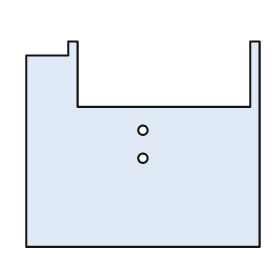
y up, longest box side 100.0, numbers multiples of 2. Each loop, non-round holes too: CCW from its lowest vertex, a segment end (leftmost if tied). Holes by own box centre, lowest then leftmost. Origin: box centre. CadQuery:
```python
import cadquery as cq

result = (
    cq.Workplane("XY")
    .moveTo(-50.0, -44.0)
    .lineTo(50.0, -44.0)
    .lineTo(50.0, 44.0)
    .lineTo(46.0, 44.0)
    .lineTo(46.0, 16.0)
    .lineTo(-28.0, 16.0)
    .lineTo(-28.0, 44.0)
    .lineTo(-32.0, 44.0)
    .lineTo(-32.0, 38.0)
    .lineTo(-50.0, 38.0)
    .close()
    .moveTo(0.0, -6.0)
    .circle(2.0)
    .moveTo(0.0, 6.0)
    .circle(2.0)
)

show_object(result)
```